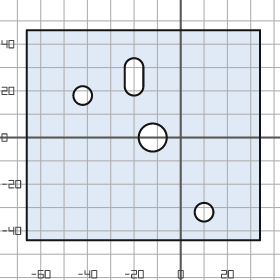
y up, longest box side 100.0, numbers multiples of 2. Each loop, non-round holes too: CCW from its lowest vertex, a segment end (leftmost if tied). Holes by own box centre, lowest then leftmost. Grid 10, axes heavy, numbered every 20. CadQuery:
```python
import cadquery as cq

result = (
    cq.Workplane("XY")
    .moveTo(-66.0, -44.0)
    .lineTo(34.0, -44.0)
    .lineTo(34.0, 46.0)
    .lineTo(-66.0, 46.0)
    .close()
    .moveTo(10.0, -32.0)
    .circle(4.0)
    .moveTo(-12.0, 0.0)
    .circle(6.0)
    .moveTo(-42.0, 18.0)
    .circle(4.0)
    .moveTo(-24.0, 22.0)
    .threePointArc((-20.0, 18.0), (-16.0, 22.0))
    .lineTo(-16.0, 30.0)
    .threePointArc((-20.0, 34.0), (-24.0, 30.0))
    .close()
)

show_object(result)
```